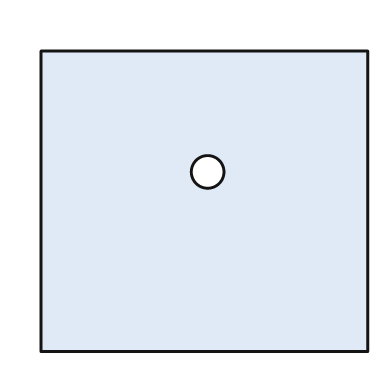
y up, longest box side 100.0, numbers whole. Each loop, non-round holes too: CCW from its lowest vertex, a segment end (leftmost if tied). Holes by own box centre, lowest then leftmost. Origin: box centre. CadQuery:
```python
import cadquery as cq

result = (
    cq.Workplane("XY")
    .moveTo(-50.0, -46.0)
    .lineTo(50.0, -46.0)
    .lineTo(50.0, 46.0)
    .lineTo(-50.0, 46.0)
    .close()
    .moveTo(1.0, 9.0)
    .circle(5.0)
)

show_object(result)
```